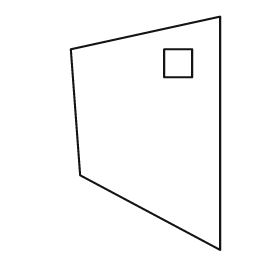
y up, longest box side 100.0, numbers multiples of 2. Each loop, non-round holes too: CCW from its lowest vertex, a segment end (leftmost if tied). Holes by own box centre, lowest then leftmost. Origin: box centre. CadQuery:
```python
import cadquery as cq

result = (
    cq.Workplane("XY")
    .moveTo(32.0, -50.0)
    .lineTo(32.0, 50.0)
    .lineTo(-32.0, 36.0)
    .lineTo(-28.0, -18.0)
    .close()
    .moveTo(8.0, 24.0)
    .lineTo(20.0, 24.0)
    .lineTo(20.0, 36.0)
    .lineTo(8.0, 36.0)
    .close()
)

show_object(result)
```